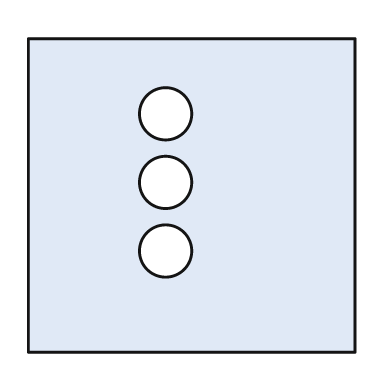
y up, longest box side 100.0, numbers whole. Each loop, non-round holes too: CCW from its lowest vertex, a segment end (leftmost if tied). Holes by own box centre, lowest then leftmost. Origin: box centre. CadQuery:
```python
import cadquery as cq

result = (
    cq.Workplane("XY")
    .moveTo(-50.0, -48.0)
    .lineTo(50.0, -48.0)
    .lineTo(50.0, 48.0)
    .lineTo(-50.0, 48.0)
    .close()
    .moveTo(-8.0, -17.0)
    .circle(8.0)
    .moveTo(-8.0, 4.0)
    .circle(8.0)
    .moveTo(-8.0, 25.0)
    .circle(8.0)
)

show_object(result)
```